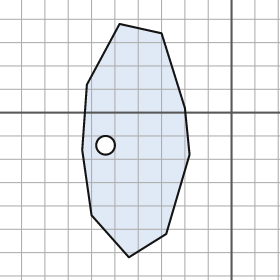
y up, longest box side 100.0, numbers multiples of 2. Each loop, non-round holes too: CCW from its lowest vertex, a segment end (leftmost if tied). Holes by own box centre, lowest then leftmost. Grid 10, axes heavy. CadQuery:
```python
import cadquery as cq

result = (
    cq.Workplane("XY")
    .moveTo(-44.0, -62.0)
    .lineTo(-28.0, -52.0)
    .lineTo(-18.0, -18.0)
    .lineTo(-20.0, 2.0)
    .lineTo(-30.0, 34.0)
    .lineTo(-48.0, 38.0)
    .lineTo(-62.0, 12.0)
    .lineTo(-64.0, -16.0)
    .lineTo(-60.0, -44.0)
    .close()
    .moveTo(-54.0, -14.0)
    .circle(4.0)
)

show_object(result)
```